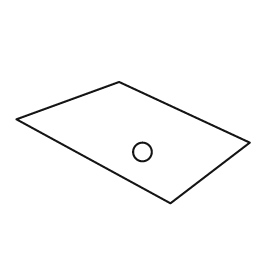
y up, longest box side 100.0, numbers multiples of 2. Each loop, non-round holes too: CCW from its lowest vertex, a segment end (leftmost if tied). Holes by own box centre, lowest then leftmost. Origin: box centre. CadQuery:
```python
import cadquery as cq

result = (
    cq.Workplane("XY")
    .moveTo(16.0, -26.0)
    .lineTo(50.0, 0.0)
    .lineTo(-6.0, 26.0)
    .lineTo(-50.0, 10.0)
    .close()
    .moveTo(4.0, -4.0)
    .circle(4.0)
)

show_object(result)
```